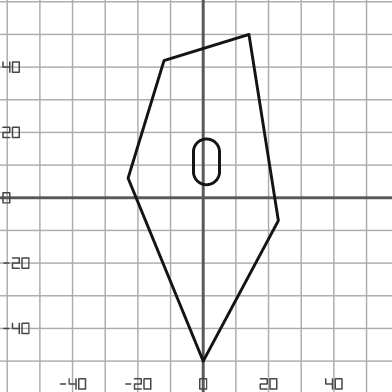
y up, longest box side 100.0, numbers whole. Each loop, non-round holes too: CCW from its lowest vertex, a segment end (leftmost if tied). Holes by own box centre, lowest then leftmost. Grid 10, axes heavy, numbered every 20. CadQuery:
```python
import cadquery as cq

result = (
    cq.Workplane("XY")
    .moveTo(0.0, -50.0)
    .lineTo(23.0, -7.0)
    .lineTo(14.0, 50.0)
    .lineTo(-12.0, 42.0)
    .lineTo(-23.0, 6.0)
    .close()
    .moveTo(-3.0, 8.0)
    .threePointArc((1.0, 4.0), (5.0, 8.0))
    .lineTo(5.0, 14.0)
    .threePointArc((1.0, 18.0), (-3.0, 14.0))
    .close()
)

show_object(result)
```